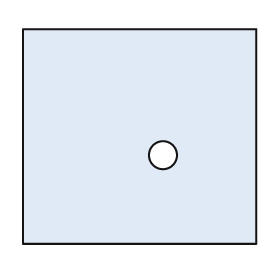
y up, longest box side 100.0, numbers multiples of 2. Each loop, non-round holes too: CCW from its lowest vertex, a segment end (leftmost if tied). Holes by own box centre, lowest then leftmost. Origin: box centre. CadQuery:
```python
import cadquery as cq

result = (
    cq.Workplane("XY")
    .moveTo(-50.0, -46.0)
    .lineTo(50.0, -46.0)
    .lineTo(50.0, 46.0)
    .lineTo(-50.0, 46.0)
    .close()
    .moveTo(10.0, -8.0)
    .circle(6.0)
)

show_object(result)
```